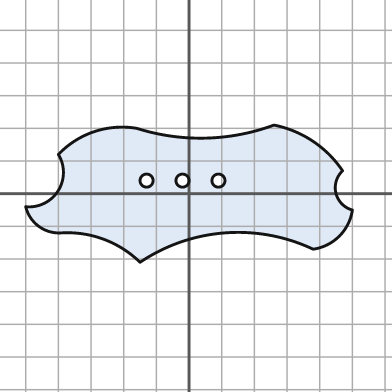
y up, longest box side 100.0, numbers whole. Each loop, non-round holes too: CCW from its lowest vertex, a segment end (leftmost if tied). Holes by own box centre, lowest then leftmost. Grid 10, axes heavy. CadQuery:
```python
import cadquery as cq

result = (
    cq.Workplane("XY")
    .moveTo(-15.0, -21.0)
    .threePointArc((11.0, -12.0), (38.0, -17.0))
    .threePointArc((46.0, -13.0), (50.0, -5.0))
    .threePointArc((45.0, 0.0), (47.0, 7.0))
    .threePointArc((38.0, 16.0), (26.0, 21.0))
    .threePointArc((5.0, 17.0), (-16.0, 20.0))
    .threePointArc((-29.0, 19.0), (-40.0, 12.0))
    .threePointArc((-40.0, 1.0), (-50.0, -4.0))
    .threePointArc((-46.0, -10.0), (-39.0, -12.0))
    .threePointArc((-26.0, -14.0), (-15.0, -21.0))
    .close()
    .moveTo(-13.0, 4.0)
    .circle(2.0)
    .moveTo(-2.0, 4.0)
    .circle(2.0)
    .moveTo(9.0, 4.0)
    .circle(2.0)
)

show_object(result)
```